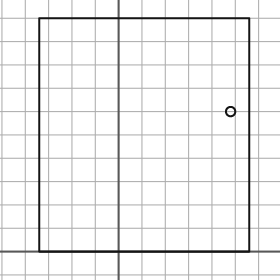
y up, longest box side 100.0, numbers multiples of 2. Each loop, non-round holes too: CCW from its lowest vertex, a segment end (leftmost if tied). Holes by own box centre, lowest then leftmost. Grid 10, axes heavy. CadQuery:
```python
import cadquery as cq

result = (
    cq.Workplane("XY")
    .moveTo(-34.0, 0.0)
    .lineTo(56.0, 0.0)
    .lineTo(56.0, 100.0)
    .lineTo(-34.0, 100.0)
    .close()
    .moveTo(48.0, 60.0)
    .circle(2.0)
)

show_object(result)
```